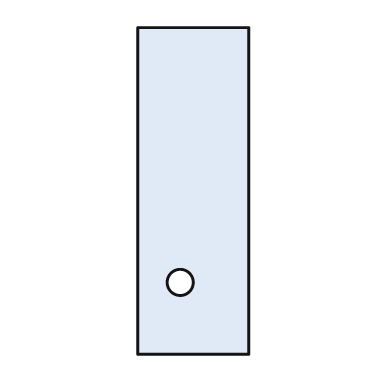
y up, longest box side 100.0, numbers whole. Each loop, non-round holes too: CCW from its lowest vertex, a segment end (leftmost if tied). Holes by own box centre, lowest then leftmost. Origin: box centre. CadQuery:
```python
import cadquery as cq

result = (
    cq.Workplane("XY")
    .moveTo(-17.0, -50.0)
    .lineTo(17.0, -50.0)
    .lineTo(17.0, 50.0)
    .lineTo(-17.0, 50.0)
    .close()
    .moveTo(-4.0, -28.0)
    .circle(4.0)
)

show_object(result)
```